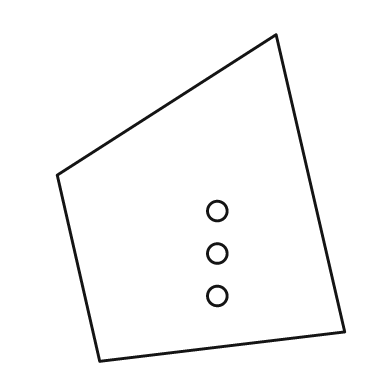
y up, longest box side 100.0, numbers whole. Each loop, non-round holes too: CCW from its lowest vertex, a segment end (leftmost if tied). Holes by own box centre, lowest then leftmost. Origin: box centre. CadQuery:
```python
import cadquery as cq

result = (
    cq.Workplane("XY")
    .moveTo(-31.0, -50.0)
    .lineTo(44.0, -41.0)
    .lineTo(23.0, 50.0)
    .lineTo(-44.0, 7.0)
    .close()
    .moveTo(5.0, -30.0)
    .circle(3.0)
    .moveTo(5.0, -17.0)
    .circle(3.0)
    .moveTo(5.0, -4.0)
    .circle(3.0)
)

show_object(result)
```